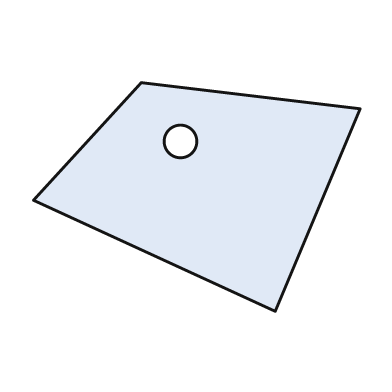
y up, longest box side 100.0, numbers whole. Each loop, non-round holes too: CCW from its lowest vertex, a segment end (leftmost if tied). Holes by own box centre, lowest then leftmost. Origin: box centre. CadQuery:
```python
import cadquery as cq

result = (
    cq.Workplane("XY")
    .moveTo(24.0, -35.0)
    .lineTo(50.0, 27.0)
    .lineTo(-17.0, 35.0)
    .lineTo(-50.0, -1.0)
    .close()
    .moveTo(-5.0, 17.0)
    .circle(5.0)
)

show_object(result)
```